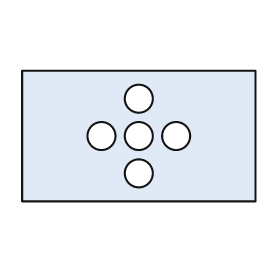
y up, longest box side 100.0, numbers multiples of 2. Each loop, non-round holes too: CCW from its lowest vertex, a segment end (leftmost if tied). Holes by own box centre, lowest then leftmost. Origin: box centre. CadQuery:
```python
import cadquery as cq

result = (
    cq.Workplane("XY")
    .moveTo(-50.0, -28.0)
    .lineTo(50.0, -28.0)
    .lineTo(50.0, 28.0)
    .lineTo(-50.0, 28.0)
    .close()
    .moveTo(0.0, -16.0)
    .circle(6.0)
    .moveTo(-16.0, 0.0)
    .circle(6.0)
    .moveTo(0.0, 0.0)
    .circle(6.0)
    .moveTo(16.0, 0.0)
    .circle(6.0)
    .moveTo(0.0, 16.0)
    .circle(6.0)
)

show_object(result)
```